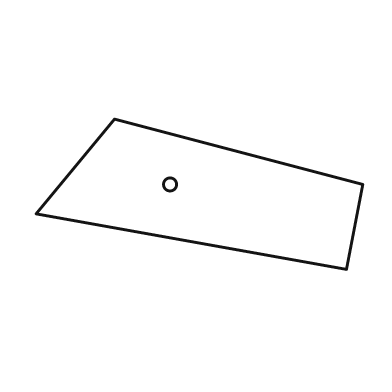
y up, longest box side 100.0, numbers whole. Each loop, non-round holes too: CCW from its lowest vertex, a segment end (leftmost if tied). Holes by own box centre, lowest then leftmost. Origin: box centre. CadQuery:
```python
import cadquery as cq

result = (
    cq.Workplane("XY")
    .moveTo(45.0, -23.0)
    .lineTo(50.0, 3.0)
    .lineTo(-26.0, 23.0)
    .lineTo(-50.0, -6.0)
    .close()
    .moveTo(-9.0, 3.0)
    .circle(2.0)
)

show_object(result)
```